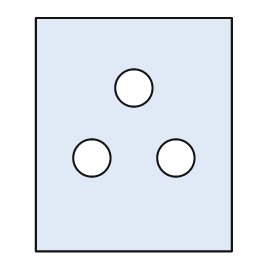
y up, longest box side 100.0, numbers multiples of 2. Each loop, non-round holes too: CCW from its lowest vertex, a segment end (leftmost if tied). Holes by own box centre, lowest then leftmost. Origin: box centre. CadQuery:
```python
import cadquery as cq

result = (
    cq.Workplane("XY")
    .moveTo(-42.0, -50.0)
    .lineTo(42.0, -50.0)
    .lineTo(42.0, 50.0)
    .lineTo(-42.0, 50.0)
    .close()
    .moveTo(-18.0, -10.0)
    .circle(8.0)
    .moveTo(18.0, -10.0)
    .circle(8.0)
    .moveTo(0.0, 20.0)
    .circle(8.0)
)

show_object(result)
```